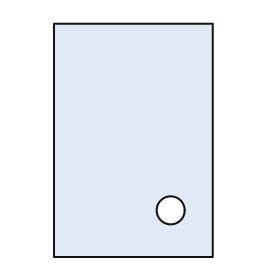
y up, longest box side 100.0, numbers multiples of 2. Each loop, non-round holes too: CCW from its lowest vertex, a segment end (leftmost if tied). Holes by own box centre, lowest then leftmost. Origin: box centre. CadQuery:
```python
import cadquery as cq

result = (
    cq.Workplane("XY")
    .moveTo(-34.0, -50.0)
    .lineTo(34.0, -50.0)
    .lineTo(34.0, 50.0)
    .lineTo(-34.0, 50.0)
    .close()
    .moveTo(16.0, -30.0)
    .circle(6.0)
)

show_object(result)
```